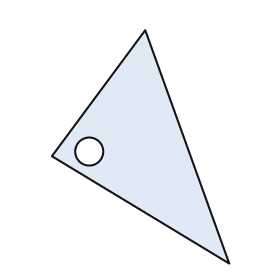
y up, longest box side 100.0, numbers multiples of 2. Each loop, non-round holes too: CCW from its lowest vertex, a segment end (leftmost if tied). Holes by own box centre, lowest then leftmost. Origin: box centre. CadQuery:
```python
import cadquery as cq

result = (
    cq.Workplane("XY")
    .moveTo(38.0, -50.0)
    .lineTo(2.0, 50.0)
    .lineTo(-38.0, -4.0)
    .close()
    .moveTo(-22.0, -2.0)
    .circle(6.0)
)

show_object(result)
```